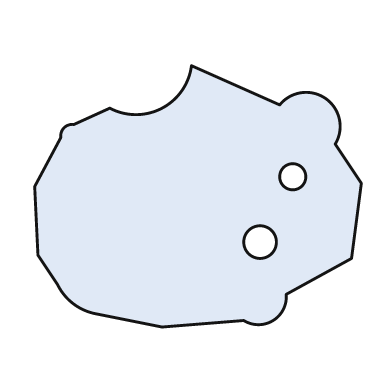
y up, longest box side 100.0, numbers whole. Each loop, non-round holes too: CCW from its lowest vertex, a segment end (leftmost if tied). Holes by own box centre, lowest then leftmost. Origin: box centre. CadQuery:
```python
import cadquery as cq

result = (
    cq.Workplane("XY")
    .moveTo(-11.0, -40.0)
    .lineTo(14.0, -38.0)
    .threePointArc((23.0, -38.0), (27.0, -30.0))
    .lineTo(47.0, -19.0)
    .lineTo(50.0, 4.0)
    .lineTo(42.0, 16.0)
    .threePointArc((39.0, 30.0), (25.0, 28.0))
    .lineTo(-2.0, 40.0)
    .threePointArc((-11.0, 27.0), (-27.0, 27.0))
    .lineTo(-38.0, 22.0)
    .threePointArc((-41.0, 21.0), (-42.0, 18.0))
    .lineTo(-50.0, 3.0)
    .lineTo(-49.0, -18.0)
    .lineTo(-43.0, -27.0)
    .threePointArc((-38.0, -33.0), (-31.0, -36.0))
    .close()
    .moveTo(19.0, -14.0)
    .circle(5.0)
    .moveTo(29.0, 6.0)
    .circle(4.0)
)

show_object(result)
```